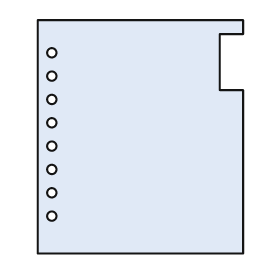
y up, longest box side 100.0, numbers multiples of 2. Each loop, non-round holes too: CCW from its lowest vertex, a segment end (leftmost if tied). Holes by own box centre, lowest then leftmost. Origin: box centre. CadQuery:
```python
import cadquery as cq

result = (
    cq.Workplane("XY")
    .moveTo(-44.0, -50.0)
    .lineTo(44.0, -50.0)
    .lineTo(44.0, 20.0)
    .lineTo(34.0, 20.0)
    .lineTo(34.0, 44.0)
    .lineTo(44.0, 44.0)
    .lineTo(44.0, 50.0)
    .lineTo(-44.0, 50.0)
    .close()
    .moveTo(-38.0, -34.0)
    .circle(2.0)
    .moveTo(-38.0, -24.0)
    .circle(2.0)
    .moveTo(-38.0, -14.0)
    .circle(2.0)
    .moveTo(-38.0, -4.0)
    .circle(2.0)
    .moveTo(-38.0, 6.0)
    .circle(2.0)
    .moveTo(-38.0, 16.0)
    .circle(2.0)
    .moveTo(-38.0, 26.0)
    .circle(2.0)
    .moveTo(-38.0, 36.0)
    .circle(2.0)
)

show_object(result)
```